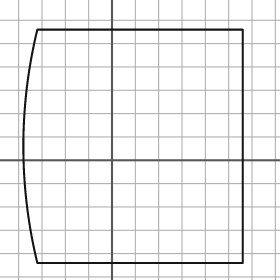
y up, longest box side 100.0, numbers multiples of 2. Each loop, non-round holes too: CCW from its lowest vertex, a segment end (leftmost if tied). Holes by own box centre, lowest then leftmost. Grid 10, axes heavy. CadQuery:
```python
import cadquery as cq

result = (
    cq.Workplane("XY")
    .moveTo(-32.0, -44.0)
    .lineTo(56.0, -44.0)
    .lineTo(56.0, 56.0)
    .lineTo(-32.0, 56.0)
    .threePointArc((-38.0, 6.0), (-32.0, -44.0))
    .close()
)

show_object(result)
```